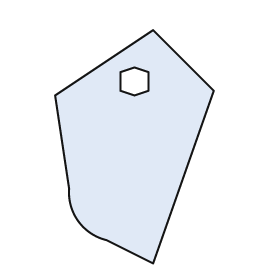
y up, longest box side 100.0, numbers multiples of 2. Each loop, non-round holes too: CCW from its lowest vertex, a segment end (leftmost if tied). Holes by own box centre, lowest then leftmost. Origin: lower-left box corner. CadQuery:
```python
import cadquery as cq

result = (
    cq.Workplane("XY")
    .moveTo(42.0, 0.0)
    .lineTo(68.0, 74.0)
    .lineTo(42.0, 100.0)
    .lineTo(0.0, 72.0)
    .lineTo(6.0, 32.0)
    .threePointArc((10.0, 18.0), (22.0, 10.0))
    .close()
    .moveTo(34.0, 72.0)
    .lineTo(40.0, 74.0)
    .lineTo(40.0, 82.0)
    .lineTo(34.0, 84.0)
    .lineTo(28.0, 82.0)
    .lineTo(28.0, 74.0)
    .close()
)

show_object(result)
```